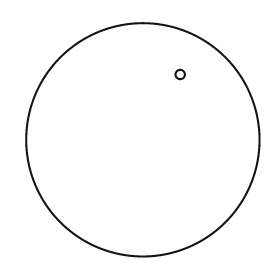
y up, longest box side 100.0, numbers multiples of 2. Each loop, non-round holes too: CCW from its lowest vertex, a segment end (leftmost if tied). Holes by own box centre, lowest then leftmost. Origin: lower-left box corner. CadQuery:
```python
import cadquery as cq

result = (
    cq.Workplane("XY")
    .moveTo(50.0, 50.0)
    .circle(50.0)
    .moveTo(66.0, 78.0)
    .circle(2.0)
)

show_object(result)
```